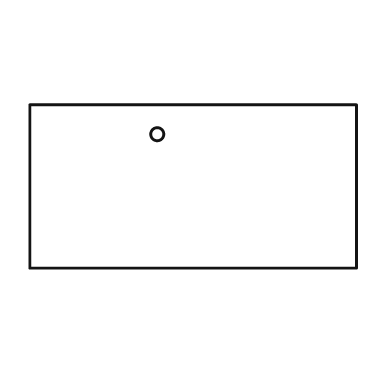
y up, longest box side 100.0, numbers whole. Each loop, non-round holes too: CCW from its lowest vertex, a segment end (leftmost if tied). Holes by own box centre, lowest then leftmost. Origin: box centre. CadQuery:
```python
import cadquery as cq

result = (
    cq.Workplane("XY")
    .moveTo(-50.0, -25.0)
    .lineTo(50.0, -25.0)
    .lineTo(50.0, 25.0)
    .lineTo(-50.0, 25.0)
    .close()
    .moveTo(-11.0, 16.0)
    .circle(2.0)
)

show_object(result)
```